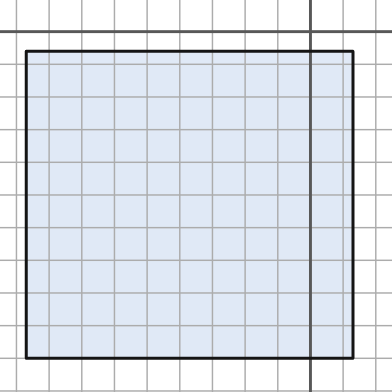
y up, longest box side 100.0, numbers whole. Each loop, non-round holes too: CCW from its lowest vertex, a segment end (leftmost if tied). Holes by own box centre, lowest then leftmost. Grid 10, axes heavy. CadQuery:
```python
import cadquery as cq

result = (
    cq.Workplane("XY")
    .moveTo(-87.0, -100.0)
    .lineTo(13.0, -100.0)
    .lineTo(13.0, -6.0)
    .lineTo(-87.0, -6.0)
    .close()
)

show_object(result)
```